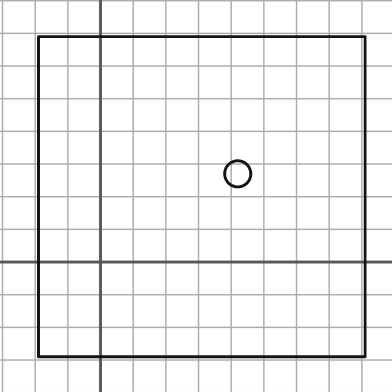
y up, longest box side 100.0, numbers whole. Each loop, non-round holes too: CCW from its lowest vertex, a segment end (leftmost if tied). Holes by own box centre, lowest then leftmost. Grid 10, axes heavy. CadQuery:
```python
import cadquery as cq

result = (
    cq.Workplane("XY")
    .moveTo(-19.0, -29.0)
    .lineTo(81.0, -29.0)
    .lineTo(81.0, 69.0)
    .lineTo(-19.0, 69.0)
    .close()
    .moveTo(42.0, 27.0)
    .circle(4.0)
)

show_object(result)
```